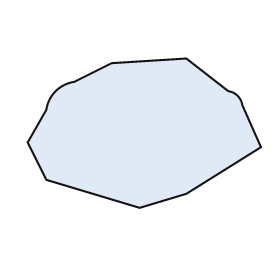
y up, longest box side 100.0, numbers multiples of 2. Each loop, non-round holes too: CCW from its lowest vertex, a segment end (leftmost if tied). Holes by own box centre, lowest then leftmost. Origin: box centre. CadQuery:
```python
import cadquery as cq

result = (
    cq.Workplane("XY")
    .moveTo(-2.0, -32.0)
    .lineTo(18.0, -26.0)
    .lineTo(50.0, -6.0)
    .lineTo(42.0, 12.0)
    .threePointArc((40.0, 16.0), (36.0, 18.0))
    .lineTo(18.0, 32.0)
    .lineTo(-14.0, 30.0)
    .lineTo(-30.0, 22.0)
    .threePointArc((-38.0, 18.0), (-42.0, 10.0))
    .lineTo(-50.0, -4.0)
    .lineTo(-42.0, -20.0)
    .close()
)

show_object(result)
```